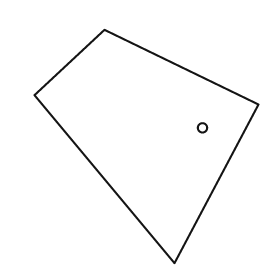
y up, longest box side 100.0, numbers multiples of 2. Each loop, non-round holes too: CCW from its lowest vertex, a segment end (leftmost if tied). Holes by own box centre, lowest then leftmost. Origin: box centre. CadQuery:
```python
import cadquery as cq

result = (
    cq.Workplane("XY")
    .moveTo(12.0, -50.0)
    .lineTo(48.0, 18.0)
    .lineTo(-18.0, 50.0)
    .lineTo(-48.0, 22.0)
    .close()
    .moveTo(24.0, 8.0)
    .circle(2.0)
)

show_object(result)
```